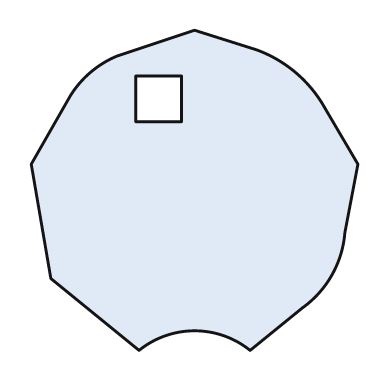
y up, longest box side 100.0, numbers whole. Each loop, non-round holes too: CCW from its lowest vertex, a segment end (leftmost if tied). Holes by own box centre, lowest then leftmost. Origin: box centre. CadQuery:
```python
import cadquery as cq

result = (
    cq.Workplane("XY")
    .moveTo(-17.0, -49.0)
    .threePointArc((0.0, -43.0), (17.0, -49.0))
    .lineTo(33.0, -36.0)
    .threePointArc((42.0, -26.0), (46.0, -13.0))
    .lineTo(50.0, 8.0)
    .lineTo(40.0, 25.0)
    .threePointArc((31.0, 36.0), (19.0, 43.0))
    .lineTo(0.0, 49.0)
    .lineTo(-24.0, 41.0)
    .threePointArc((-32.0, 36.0), (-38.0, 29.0))
    .lineTo(-50.0, 8.0)
    .lineTo(-44.0, -27.0)
    .close()
    .moveTo(-18.0, 21.0)
    .lineTo(-4.0, 21.0)
    .lineTo(-4.0, 35.0)
    .lineTo(-18.0, 35.0)
    .close()
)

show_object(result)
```